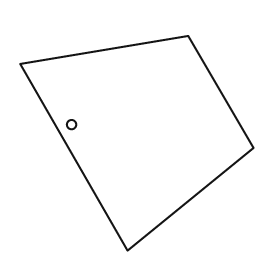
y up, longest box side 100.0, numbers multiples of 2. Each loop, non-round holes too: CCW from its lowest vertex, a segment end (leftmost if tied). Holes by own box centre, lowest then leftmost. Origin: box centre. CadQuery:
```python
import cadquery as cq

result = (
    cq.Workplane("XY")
    .moveTo(-4.0, -46.0)
    .lineTo(50.0, -2.0)
    .lineTo(22.0, 46.0)
    .lineTo(-50.0, 34.0)
    .close()
    .moveTo(-28.0, 8.0)
    .circle(2.0)
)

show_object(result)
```